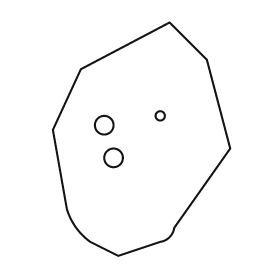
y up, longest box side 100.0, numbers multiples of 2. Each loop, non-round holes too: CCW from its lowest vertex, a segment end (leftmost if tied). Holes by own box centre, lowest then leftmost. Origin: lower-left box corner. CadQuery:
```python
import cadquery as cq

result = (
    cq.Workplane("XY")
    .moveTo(28.0, 0.0)
    .lineTo(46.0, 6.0)
    .threePointArc((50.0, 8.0), (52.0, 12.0))
    .lineTo(76.0, 46.0)
    .lineTo(66.0, 84.0)
    .lineTo(50.0, 100.0)
    .lineTo(12.0, 80.0)
    .lineTo(0.0, 54.0)
    .lineTo(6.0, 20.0)
    .threePointArc((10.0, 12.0), (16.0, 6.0))
    .close()
    .moveTo(26.0, 42.0)
    .circle(4.0)
    .moveTo(22.0, 56.0)
    .circle(4.0)
    .moveTo(46.0, 60.0)
    .circle(2.0)
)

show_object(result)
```